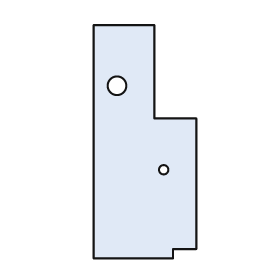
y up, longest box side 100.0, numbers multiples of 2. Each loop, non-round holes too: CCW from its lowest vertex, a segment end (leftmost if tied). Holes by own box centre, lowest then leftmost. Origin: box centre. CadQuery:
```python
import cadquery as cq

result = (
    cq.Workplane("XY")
    .moveTo(-22.0, -50.0)
    .lineTo(12.0, -50.0)
    .lineTo(12.0, -46.0)
    .lineTo(22.0, -46.0)
    .lineTo(22.0, 10.0)
    .lineTo(4.0, 10.0)
    .lineTo(4.0, 50.0)
    .lineTo(-22.0, 50.0)
    .close()
    .moveTo(8.0, -12.0)
    .circle(2.0)
    .moveTo(-12.0, 24.0)
    .circle(4.0)
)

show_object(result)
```